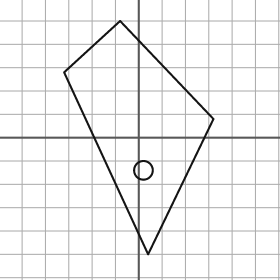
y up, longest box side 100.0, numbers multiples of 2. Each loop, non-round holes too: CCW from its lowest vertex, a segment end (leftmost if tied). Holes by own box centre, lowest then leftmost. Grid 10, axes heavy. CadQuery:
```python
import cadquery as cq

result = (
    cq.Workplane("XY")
    .moveTo(4.0, -50.0)
    .lineTo(32.0, 8.0)
    .lineTo(-8.0, 50.0)
    .lineTo(-32.0, 28.0)
    .close()
    .moveTo(2.0, -14.0)
    .circle(4.0)
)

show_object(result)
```